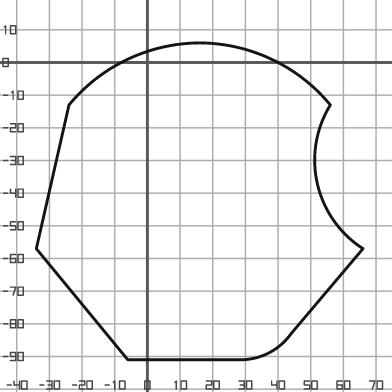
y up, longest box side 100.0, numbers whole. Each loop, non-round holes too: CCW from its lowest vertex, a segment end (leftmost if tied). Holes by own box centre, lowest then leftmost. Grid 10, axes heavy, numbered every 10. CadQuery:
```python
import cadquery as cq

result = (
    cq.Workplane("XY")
    .moveTo(-6.0, -91.0)
    .lineTo(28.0, -91.0)
    .threePointArc((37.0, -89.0), (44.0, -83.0))
    .lineTo(66.0, -57.0)
    .threePointArc((52.0, -37.0), (56.0, -13.0))
    .threePointArc((38.0, 1.0), (16.0, 6.0))
    .threePointArc((-6.0, 1.0), (-24.0, -13.0))
    .lineTo(-34.0, -57.0)
    .close()
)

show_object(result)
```